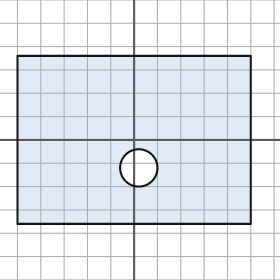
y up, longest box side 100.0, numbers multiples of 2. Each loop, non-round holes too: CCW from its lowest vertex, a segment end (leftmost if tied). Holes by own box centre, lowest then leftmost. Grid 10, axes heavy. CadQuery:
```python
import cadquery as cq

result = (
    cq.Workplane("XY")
    .moveTo(-50.0, -36.0)
    .lineTo(50.0, -36.0)
    .lineTo(50.0, 36.0)
    .lineTo(-50.0, 36.0)
    .close()
    .moveTo(2.0, -12.0)
    .circle(8.0)
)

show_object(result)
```